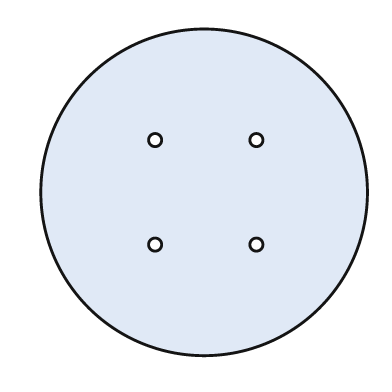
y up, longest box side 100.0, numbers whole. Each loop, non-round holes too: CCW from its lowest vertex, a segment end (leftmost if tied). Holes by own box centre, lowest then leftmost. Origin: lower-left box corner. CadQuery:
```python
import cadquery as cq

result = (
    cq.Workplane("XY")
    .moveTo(50.0, 50.0)
    .circle(50.0)
    .moveTo(35.0, 34.0)
    .circle(2.0)
    .moveTo(66.0, 34.0)
    .circle(2.0)
    .moveTo(35.0, 66.0)
    .circle(2.0)
    .moveTo(66.0, 66.0)
    .circle(2.0)
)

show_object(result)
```